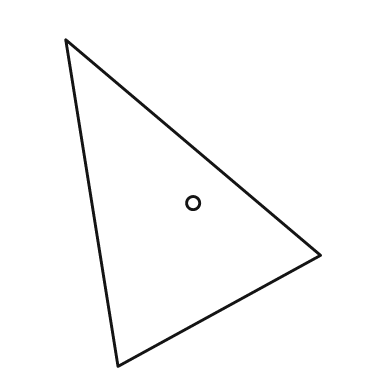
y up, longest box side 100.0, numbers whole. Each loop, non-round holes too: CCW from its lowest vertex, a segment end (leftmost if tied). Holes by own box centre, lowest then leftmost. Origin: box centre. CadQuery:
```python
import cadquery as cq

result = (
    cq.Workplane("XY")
    .moveTo(-23.0, -50.0)
    .lineTo(39.0, -16.0)
    .lineTo(-39.0, 50.0)
    .close()
    .moveTo(0.0, 0.0)
    .circle(2.0)
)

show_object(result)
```